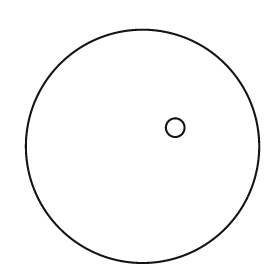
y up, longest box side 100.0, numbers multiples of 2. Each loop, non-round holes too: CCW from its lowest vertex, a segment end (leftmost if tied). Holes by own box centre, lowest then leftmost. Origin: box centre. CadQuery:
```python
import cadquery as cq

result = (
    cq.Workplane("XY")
    .moveTo(0.0, 0.0)
    .circle(50.0)
    .moveTo(14.0, 8.0)
    .circle(4.0)
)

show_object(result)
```